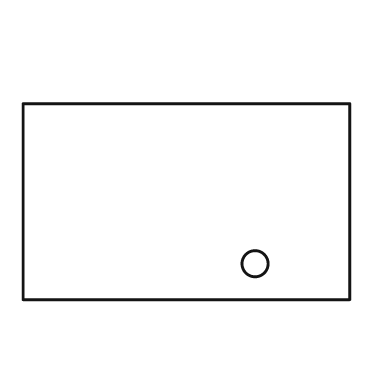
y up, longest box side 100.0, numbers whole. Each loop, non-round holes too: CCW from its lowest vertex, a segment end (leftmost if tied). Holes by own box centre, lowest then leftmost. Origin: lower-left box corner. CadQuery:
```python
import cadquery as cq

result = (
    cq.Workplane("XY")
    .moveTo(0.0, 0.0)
    .lineTo(100.0, 0.0)
    .lineTo(100.0, 60.0)
    .lineTo(0.0, 60.0)
    .close()
    .moveTo(71.0, 11.0)
    .circle(4.0)
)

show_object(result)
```